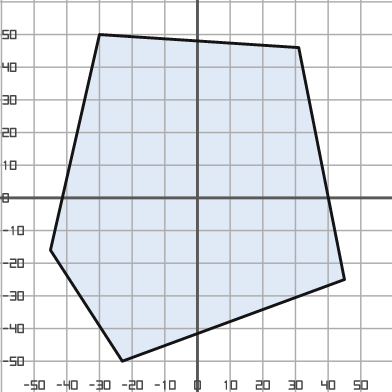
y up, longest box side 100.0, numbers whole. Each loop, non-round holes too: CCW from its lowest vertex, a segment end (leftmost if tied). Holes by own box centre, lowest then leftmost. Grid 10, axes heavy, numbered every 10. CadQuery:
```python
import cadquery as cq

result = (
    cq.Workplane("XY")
    .moveTo(-23.0, -50.0)
    .lineTo(45.0, -25.0)
    .lineTo(31.0, 46.0)
    .lineTo(-30.0, 50.0)
    .lineTo(-45.0, -16.0)
    .close()
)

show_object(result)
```